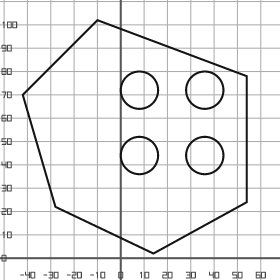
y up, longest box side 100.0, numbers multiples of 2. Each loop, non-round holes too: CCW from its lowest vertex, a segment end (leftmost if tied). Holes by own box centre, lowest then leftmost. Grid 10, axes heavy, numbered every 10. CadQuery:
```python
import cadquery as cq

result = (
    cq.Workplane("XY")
    .moveTo(14.0, 2.0)
    .lineTo(54.0, 24.0)
    .lineTo(54.0, 78.0)
    .lineTo(-10.0, 102.0)
    .lineTo(-42.0, 70.0)
    .lineTo(-28.0, 22.0)
    .close()
    .moveTo(8.0, 44.0)
    .circle(8.0)
    .moveTo(36.0, 44.0)
    .circle(8.0)
    .moveTo(8.0, 72.0)
    .circle(8.0)
    .moveTo(36.0, 72.0)
    .circle(8.0)
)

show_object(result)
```